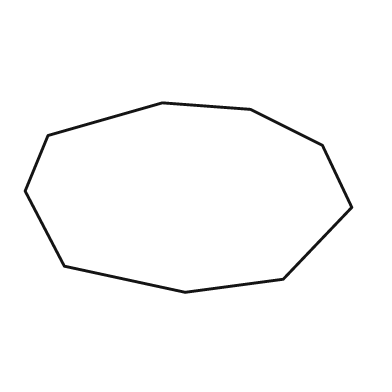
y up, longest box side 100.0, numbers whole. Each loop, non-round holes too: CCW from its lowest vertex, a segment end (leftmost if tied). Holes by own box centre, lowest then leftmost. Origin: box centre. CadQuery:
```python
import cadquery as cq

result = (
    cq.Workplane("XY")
    .moveTo(-1.0, -29.0)
    .lineTo(29.0, -25.0)
    .lineTo(50.0, -3.0)
    .lineTo(41.0, 16.0)
    .lineTo(19.0, 27.0)
    .lineTo(-8.0, 29.0)
    .lineTo(-43.0, 19.0)
    .lineTo(-50.0, 2.0)
    .lineTo(-38.0, -21.0)
    .close()
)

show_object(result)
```